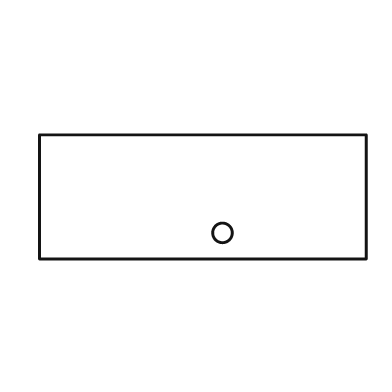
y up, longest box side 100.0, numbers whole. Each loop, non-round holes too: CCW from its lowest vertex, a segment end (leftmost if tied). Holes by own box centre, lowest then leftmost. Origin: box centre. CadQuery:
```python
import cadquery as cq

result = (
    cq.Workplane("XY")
    .moveTo(-50.0, -19.0)
    .lineTo(50.0, -19.0)
    .lineTo(50.0, 19.0)
    .lineTo(-50.0, 19.0)
    .close()
    .moveTo(6.0, -11.0)
    .circle(3.0)
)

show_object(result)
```